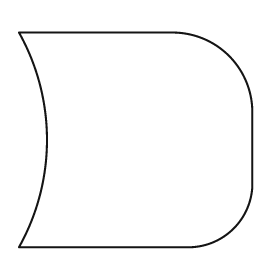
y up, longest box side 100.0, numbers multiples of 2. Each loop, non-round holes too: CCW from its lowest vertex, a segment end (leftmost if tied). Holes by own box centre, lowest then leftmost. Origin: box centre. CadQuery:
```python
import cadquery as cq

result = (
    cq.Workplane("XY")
    .moveTo(-50.0, -46.0)
    .lineTo(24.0, -46.0)
    .threePointArc((42.0, -38.0), (50.0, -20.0))
    .lineTo(50.0, 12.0)
    .threePointArc((40.0, 36.0), (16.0, 46.0))
    .lineTo(-50.0, 46.0)
    .threePointArc((-38.0, 0.0), (-50.0, -46.0))
    .close()
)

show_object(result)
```